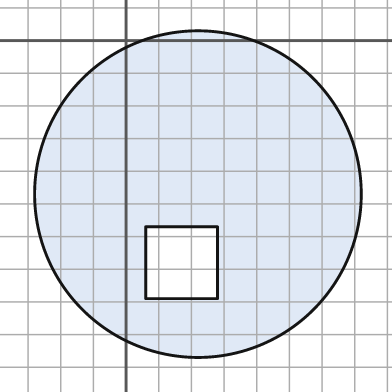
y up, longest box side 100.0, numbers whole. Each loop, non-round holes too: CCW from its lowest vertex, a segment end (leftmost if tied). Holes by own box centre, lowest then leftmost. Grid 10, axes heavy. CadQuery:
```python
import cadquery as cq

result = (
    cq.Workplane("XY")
    .moveTo(22.0, -47.0)
    .circle(50.0)
    .moveTo(6.0, -79.0)
    .lineTo(28.0, -79.0)
    .lineTo(28.0, -57.0)
    .lineTo(6.0, -57.0)
    .close()
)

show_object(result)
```